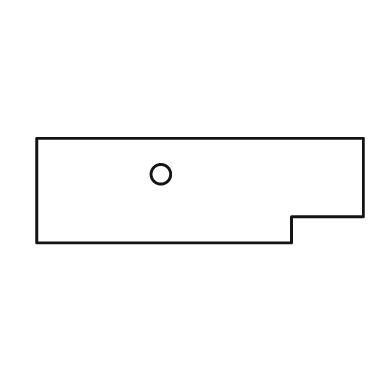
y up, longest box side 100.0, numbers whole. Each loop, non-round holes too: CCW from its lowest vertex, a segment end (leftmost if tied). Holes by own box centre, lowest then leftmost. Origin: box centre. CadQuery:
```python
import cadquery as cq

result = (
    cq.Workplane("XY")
    .moveTo(-50.0, -16.0)
    .lineTo(28.0, -16.0)
    .lineTo(28.0, -8.0)
    .lineTo(50.0, -8.0)
    .lineTo(50.0, 16.0)
    .lineTo(-50.0, 16.0)
    .close()
    .moveTo(-12.0, 5.0)
    .circle(3.0)
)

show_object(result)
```